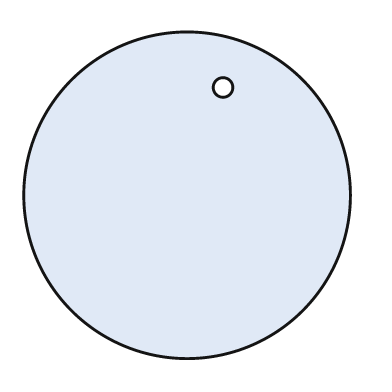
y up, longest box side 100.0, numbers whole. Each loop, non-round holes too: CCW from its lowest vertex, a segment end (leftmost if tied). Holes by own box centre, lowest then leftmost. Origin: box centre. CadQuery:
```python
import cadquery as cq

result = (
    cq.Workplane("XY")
    .moveTo(0.0, 0.0)
    .circle(50.0)
    .moveTo(11.0, 33.0)
    .circle(3.0)
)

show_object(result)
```